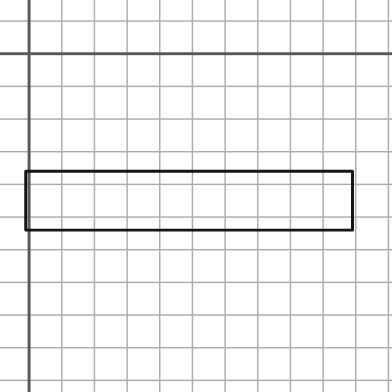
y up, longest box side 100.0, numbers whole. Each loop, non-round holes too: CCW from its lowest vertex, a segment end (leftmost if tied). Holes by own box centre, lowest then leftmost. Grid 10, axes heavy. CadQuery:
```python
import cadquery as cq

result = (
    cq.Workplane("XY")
    .moveTo(-1.0, -54.0)
    .lineTo(99.0, -54.0)
    .lineTo(99.0, -36.0)
    .lineTo(-1.0, -36.0)
    .close()
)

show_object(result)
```